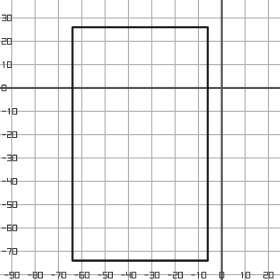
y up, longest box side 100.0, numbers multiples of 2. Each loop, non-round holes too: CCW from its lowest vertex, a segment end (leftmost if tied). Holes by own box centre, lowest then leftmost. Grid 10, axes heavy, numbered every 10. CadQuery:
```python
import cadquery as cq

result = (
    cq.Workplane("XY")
    .moveTo(-64.0, -74.0)
    .lineTo(-6.0, -74.0)
    .lineTo(-6.0, 26.0)
    .lineTo(-64.0, 26.0)
    .close()
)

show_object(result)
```